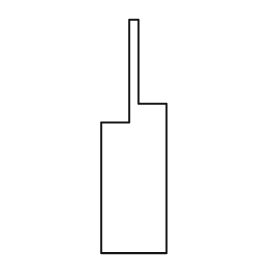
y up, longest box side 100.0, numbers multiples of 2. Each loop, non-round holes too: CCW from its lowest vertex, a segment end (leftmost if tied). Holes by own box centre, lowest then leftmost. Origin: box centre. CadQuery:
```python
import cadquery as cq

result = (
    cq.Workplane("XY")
    .moveTo(-14.0, -50.0)
    .lineTo(14.0, -50.0)
    .lineTo(14.0, 14.0)
    .lineTo(2.0, 14.0)
    .lineTo(2.0, 50.0)
    .lineTo(-2.0, 50.0)
    .lineTo(-2.0, 6.0)
    .lineTo(-14.0, 6.0)
    .close()
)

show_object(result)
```